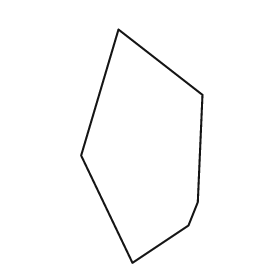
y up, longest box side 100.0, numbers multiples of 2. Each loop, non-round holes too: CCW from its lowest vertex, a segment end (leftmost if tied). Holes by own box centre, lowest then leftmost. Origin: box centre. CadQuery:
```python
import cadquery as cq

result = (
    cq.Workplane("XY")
    .moveTo(-4.0, -50.0)
    .lineTo(20.0, -34.0)
    .lineTo(24.0, -24.0)
    .lineTo(26.0, 22.0)
    .lineTo(-10.0, 50.0)
    .lineTo(-26.0, -4.0)
    .close()
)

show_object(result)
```